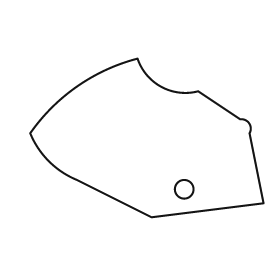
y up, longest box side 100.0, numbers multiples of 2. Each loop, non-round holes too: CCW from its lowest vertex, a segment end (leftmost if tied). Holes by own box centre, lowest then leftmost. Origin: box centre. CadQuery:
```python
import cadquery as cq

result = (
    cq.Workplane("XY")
    .moveTo(2.0, -34.0)
    .lineTo(50.0, -28.0)
    .lineTo(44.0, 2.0)
    .threePointArc((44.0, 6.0), (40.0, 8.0))
    .lineTo(22.0, 20.0)
    .threePointArc((6.0, 22.0), (-4.0, 34.0))
    .threePointArc((-30.0, 22.0), (-50.0, 2.0))
    .threePointArc((-42.0, -10.0), (-30.0, -18.0))
    .close()
    .moveTo(16.0, -22.0)
    .circle(4.0)
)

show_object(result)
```